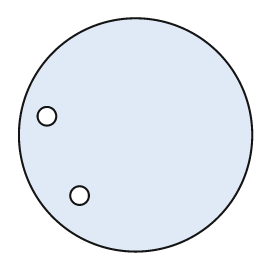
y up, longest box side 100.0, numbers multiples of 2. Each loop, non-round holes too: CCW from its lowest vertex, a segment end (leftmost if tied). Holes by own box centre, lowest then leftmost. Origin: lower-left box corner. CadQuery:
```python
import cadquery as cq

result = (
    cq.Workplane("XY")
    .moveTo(50.0, 50.0)
    .circle(50.0)
    .moveTo(26.0, 24.0)
    .circle(4.0)
    .moveTo(12.0, 58.0)
    .circle(4.0)
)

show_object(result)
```